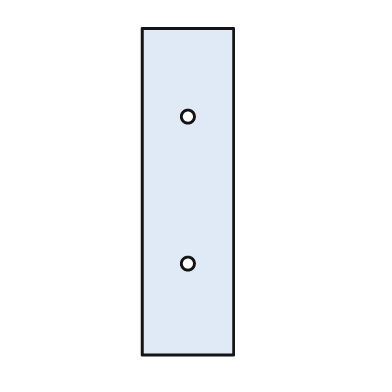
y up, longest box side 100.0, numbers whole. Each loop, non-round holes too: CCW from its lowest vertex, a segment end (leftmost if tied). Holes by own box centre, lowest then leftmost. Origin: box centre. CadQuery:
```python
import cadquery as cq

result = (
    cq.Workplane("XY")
    .moveTo(-14.0, -50.0)
    .lineTo(14.0, -50.0)
    .lineTo(14.0, 50.0)
    .lineTo(-14.0, 50.0)
    .close()
    .moveTo(0.0, -22.0)
    .circle(2.0)
    .moveTo(0.0, 23.0)
    .circle(2.0)
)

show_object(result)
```